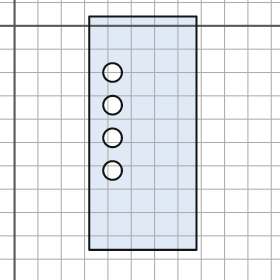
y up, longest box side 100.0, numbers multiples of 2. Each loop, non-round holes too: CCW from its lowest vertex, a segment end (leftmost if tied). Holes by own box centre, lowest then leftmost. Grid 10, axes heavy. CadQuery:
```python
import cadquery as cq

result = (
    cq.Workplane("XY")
    .moveTo(32.0, -96.0)
    .lineTo(78.0, -96.0)
    .lineTo(78.0, 4.0)
    .lineTo(32.0, 4.0)
    .close()
    .moveTo(42.0, -62.0)
    .circle(4.0)
    .moveTo(42.0, -48.0)
    .circle(4.0)
    .moveTo(42.0, -34.0)
    .circle(4.0)
    .moveTo(42.0, -20.0)
    .circle(4.0)
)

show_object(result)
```